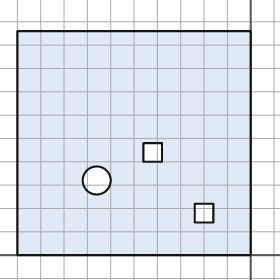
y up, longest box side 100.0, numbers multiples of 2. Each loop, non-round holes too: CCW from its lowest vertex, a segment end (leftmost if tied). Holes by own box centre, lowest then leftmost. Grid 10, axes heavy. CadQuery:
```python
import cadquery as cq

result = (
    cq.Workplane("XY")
    .moveTo(-100.0, 0.0)
    .lineTo(0.0, 0.0)
    .lineTo(0.0, 96.0)
    .lineTo(-100.0, 96.0)
    .close()
    .moveTo(-24.0, 14.0)
    .lineTo(-16.0, 14.0)
    .lineTo(-16.0, 22.0)
    .lineTo(-24.0, 22.0)
    .close()
    .moveTo(-66.0, 32.0)
    .circle(6.0)
    .moveTo(-46.0, 40.0)
    .lineTo(-38.0, 40.0)
    .lineTo(-38.0, 48.0)
    .lineTo(-46.0, 48.0)
    .close()
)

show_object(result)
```